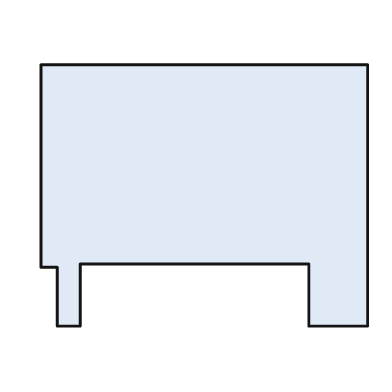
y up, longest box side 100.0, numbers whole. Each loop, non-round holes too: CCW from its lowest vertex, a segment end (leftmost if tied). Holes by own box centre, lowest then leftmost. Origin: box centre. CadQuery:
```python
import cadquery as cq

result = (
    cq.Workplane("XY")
    .moveTo(-45.0, -40.0)
    .lineTo(-38.0, -40.0)
    .lineTo(-38.0, -21.0)
    .lineTo(32.0, -21.0)
    .lineTo(32.0, -40.0)
    .lineTo(50.0, -40.0)
    .lineTo(50.0, 40.0)
    .lineTo(-50.0, 40.0)
    .lineTo(-50.0, -22.0)
    .lineTo(-45.0, -22.0)
    .close()
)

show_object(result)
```